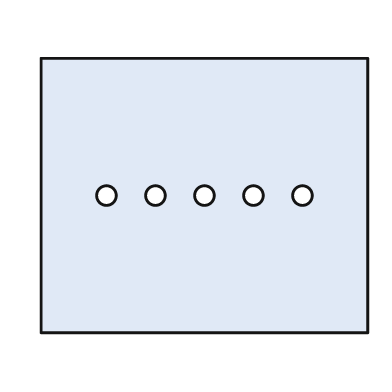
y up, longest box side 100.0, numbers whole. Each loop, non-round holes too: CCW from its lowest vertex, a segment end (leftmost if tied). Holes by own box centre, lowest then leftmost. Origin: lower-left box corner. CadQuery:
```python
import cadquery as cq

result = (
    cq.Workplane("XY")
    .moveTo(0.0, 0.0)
    .lineTo(100.0, 0.0)
    .lineTo(100.0, 84.0)
    .lineTo(0.0, 84.0)
    .close()
    .moveTo(20.0, 42.0)
    .circle(3.0)
    .moveTo(35.0, 42.0)
    .circle(3.0)
    .moveTo(50.0, 42.0)
    .circle(3.0)
    .moveTo(65.0, 42.0)
    .circle(3.0)
    .moveTo(80.0, 42.0)
    .circle(3.0)
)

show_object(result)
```